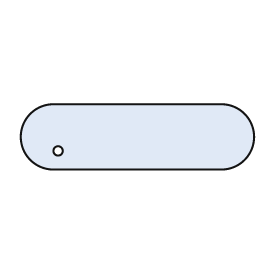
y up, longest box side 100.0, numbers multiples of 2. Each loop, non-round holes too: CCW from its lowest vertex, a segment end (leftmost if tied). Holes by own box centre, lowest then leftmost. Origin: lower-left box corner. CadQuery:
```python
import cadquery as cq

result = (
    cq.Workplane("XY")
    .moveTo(14.0, 0.0)
    .lineTo(86.0, 0.0)
    .threePointArc((100.0, 14.0), (86.0, 28.0))
    .lineTo(14.0, 28.0)
    .threePointArc((0.0, 14.0), (14.0, 0.0))
    .close()
    .moveTo(16.0, 8.0)
    .circle(2.0)
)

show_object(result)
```